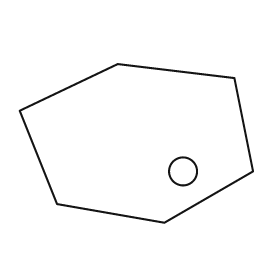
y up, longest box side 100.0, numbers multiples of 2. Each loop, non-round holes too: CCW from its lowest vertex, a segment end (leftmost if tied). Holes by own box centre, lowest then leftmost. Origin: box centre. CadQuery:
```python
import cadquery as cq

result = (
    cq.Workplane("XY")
    .moveTo(12.0, -34.0)
    .lineTo(50.0, -12.0)
    .lineTo(42.0, 28.0)
    .lineTo(-8.0, 34.0)
    .lineTo(-50.0, 14.0)
    .lineTo(-34.0, -26.0)
    .close()
    .moveTo(20.0, -12.0)
    .circle(6.0)
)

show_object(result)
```